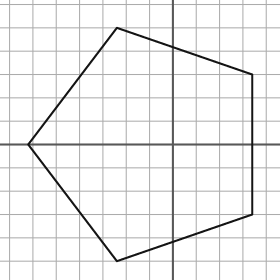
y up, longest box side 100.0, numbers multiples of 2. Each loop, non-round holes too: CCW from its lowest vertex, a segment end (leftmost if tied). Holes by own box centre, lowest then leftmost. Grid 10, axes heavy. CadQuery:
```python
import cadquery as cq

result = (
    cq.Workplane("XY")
    .moveTo(-24.0, -50.0)
    .lineTo(34.0, -30.0)
    .lineTo(34.0, 30.0)
    .lineTo(-24.0, 50.0)
    .lineTo(-62.0, 0.0)
    .close()
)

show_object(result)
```